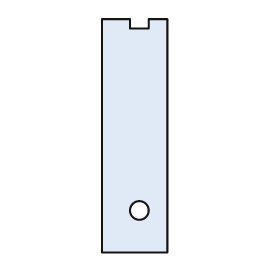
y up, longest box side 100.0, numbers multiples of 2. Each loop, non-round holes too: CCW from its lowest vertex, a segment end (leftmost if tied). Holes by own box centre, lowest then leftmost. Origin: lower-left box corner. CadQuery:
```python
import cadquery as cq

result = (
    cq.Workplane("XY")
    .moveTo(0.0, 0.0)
    .lineTo(28.0, 0.0)
    .lineTo(28.0, 100.0)
    .lineTo(20.0, 100.0)
    .lineTo(20.0, 96.0)
    .lineTo(12.0, 96.0)
    .lineTo(12.0, 100.0)
    .lineTo(0.0, 100.0)
    .close()
    .moveTo(16.0, 18.0)
    .circle(4.0)
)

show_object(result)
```